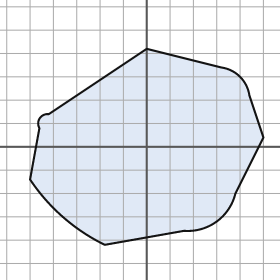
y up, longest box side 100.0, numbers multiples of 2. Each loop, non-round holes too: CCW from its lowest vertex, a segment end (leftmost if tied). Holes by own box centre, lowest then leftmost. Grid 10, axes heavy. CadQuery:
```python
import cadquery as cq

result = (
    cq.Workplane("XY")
    .moveTo(-18.0, -42.0)
    .lineTo(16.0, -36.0)
    .threePointArc((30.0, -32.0), (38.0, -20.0))
    .lineTo(50.0, 4.0)
    .lineTo(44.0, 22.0)
    .threePointArc((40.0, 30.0), (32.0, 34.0))
    .lineTo(0.0, 42.0)
    .lineTo(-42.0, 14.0)
    .threePointArc((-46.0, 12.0), (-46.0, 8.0))
    .lineTo(-50.0, -14.0)
    .threePointArc((-36.0, -30.0), (-18.0, -42.0))
    .close()
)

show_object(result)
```